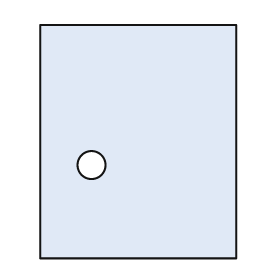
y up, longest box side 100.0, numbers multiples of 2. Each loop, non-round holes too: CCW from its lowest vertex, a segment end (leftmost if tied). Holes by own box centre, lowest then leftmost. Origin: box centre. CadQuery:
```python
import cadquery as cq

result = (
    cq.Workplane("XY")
    .moveTo(-42.0, -50.0)
    .lineTo(42.0, -50.0)
    .lineTo(42.0, 50.0)
    .lineTo(-42.0, 50.0)
    .close()
    .moveTo(-20.0, -10.0)
    .circle(6.0)
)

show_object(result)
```